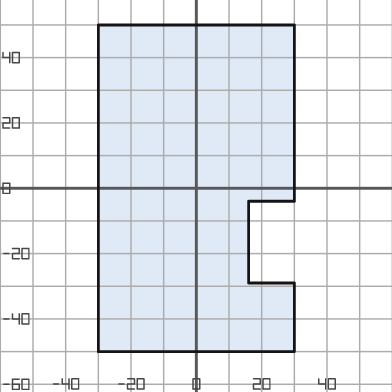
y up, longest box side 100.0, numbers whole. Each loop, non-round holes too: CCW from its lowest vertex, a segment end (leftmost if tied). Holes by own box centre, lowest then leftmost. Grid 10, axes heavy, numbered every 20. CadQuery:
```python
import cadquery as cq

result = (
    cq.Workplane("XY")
    .moveTo(-30.0, -50.0)
    .lineTo(30.0, -50.0)
    .lineTo(30.0, -29.0)
    .lineTo(16.0, -29.0)
    .lineTo(16.0, -4.0)
    .lineTo(30.0, -4.0)
    .lineTo(30.0, 50.0)
    .lineTo(-30.0, 50.0)
    .close()
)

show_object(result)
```